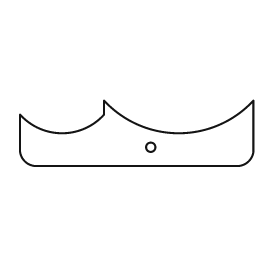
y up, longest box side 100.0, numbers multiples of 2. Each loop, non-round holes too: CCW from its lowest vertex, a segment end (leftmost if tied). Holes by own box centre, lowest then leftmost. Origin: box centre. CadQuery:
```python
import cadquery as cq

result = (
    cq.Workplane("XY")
    .moveTo(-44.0, -14.0)
    .lineTo(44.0, -14.0)
    .threePointArc((48.0, -12.0), (50.0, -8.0))
    .lineTo(50.0, 14.0)
    .threePointArc((18.0, 0.0), (-14.0, 14.0))
    .lineTo(-14.0, 8.0)
    .threePointArc((-32.0, 0.0), (-50.0, 8.0))
    .lineTo(-50.0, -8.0)
    .threePointArc((-48.0, -12.0), (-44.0, -14.0))
    .close()
    .moveTo(6.0, -6.0)
    .circle(2.0)
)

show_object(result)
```